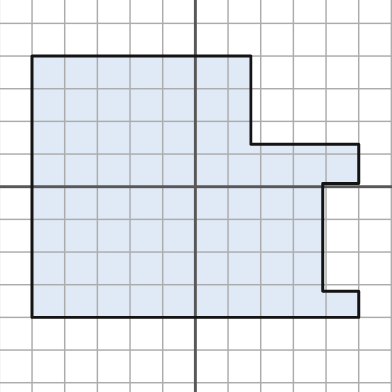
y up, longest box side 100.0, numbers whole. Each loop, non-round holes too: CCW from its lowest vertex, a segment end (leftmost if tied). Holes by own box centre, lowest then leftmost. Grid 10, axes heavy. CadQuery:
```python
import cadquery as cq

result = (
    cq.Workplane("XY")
    .moveTo(-50.0, -40.0)
    .lineTo(50.0, -40.0)
    .lineTo(50.0, -32.0)
    .lineTo(39.0, -32.0)
    .lineTo(39.0, 1.0)
    .lineTo(50.0, 1.0)
    .lineTo(50.0, 13.0)
    .lineTo(17.0, 13.0)
    .lineTo(17.0, 40.0)
    .lineTo(-50.0, 40.0)
    .close()
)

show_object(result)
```